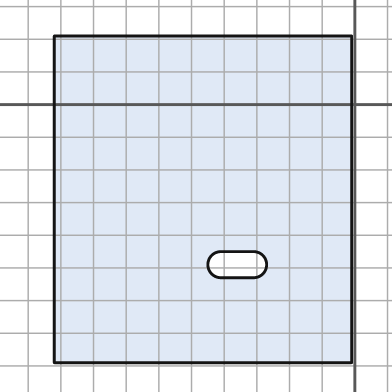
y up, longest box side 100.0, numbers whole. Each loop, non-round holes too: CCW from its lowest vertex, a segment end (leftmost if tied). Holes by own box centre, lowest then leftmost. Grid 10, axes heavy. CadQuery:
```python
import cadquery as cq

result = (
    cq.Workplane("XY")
    .moveTo(-92.0, -79.0)
    .lineTo(-1.0, -79.0)
    .lineTo(-1.0, 21.0)
    .lineTo(-92.0, 21.0)
    .close()
    .moveTo(-41.0, -53.0)
    .lineTo(-31.0, -53.0)
    .threePointArc((-27.0, -49.0), (-31.0, -45.0))
    .lineTo(-41.0, -45.0)
    .threePointArc((-45.0, -49.0), (-41.0, -53.0))
    .close()
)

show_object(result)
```